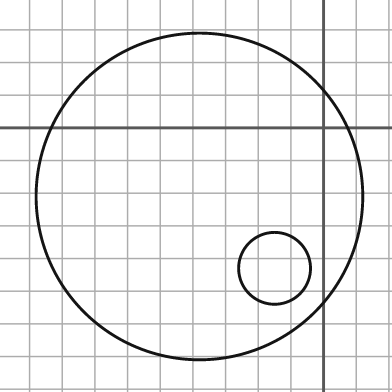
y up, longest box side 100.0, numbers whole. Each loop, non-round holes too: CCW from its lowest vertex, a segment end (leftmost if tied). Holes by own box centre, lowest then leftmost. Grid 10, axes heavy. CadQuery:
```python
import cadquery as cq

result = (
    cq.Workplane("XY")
    .moveTo(-38.0, -21.0)
    .circle(50.0)
    .moveTo(-15.0, -43.0)
    .circle(11.0)
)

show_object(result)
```